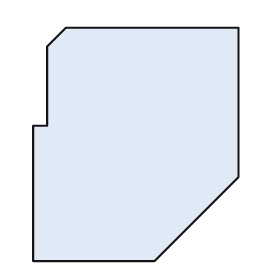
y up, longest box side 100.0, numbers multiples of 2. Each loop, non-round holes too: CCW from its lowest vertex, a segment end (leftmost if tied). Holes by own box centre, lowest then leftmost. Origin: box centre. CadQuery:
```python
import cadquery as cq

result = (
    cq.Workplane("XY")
    .moveTo(-44.0, -50.0)
    .lineTo(8.0, -50.0)
    .lineTo(44.0, -14.0)
    .lineTo(44.0, 50.0)
    .lineTo(-30.0, 50.0)
    .lineTo(-38.0, 42.0)
    .lineTo(-38.0, 8.0)
    .lineTo(-44.0, 8.0)
    .close()
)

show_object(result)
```